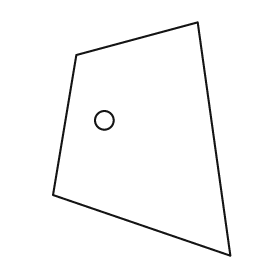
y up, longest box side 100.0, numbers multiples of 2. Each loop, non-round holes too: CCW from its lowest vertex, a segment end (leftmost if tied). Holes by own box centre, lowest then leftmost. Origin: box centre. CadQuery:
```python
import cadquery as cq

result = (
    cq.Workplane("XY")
    .moveTo(38.0, -50.0)
    .lineTo(24.0, 50.0)
    .lineTo(-28.0, 36.0)
    .lineTo(-38.0, -24.0)
    .close()
    .moveTo(-16.0, 8.0)
    .circle(4.0)
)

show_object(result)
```